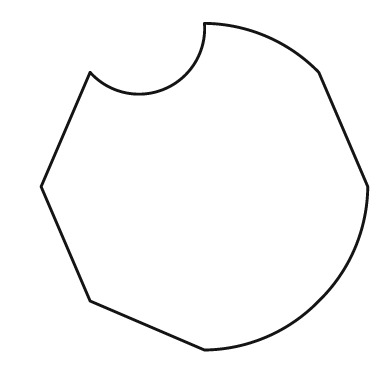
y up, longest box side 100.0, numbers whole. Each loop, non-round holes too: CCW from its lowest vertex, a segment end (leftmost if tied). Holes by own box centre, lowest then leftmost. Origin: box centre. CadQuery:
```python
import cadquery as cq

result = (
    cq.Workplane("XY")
    .moveTo(0.0, -50.0)
    .threePointArc((19.0, -46.0), (35.0, -35.0))
    .threePointArc((46.0, -19.0), (50.0, 0.0))
    .lineTo(35.0, 35.0)
    .threePointArc((19.0, 46.0), (0.0, 50.0))
    .threePointArc((-12.0, 30.0), (-35.0, 35.0))
    .lineTo(-50.0, 0.0)
    .lineTo(-35.0, -35.0)
    .close()
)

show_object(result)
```